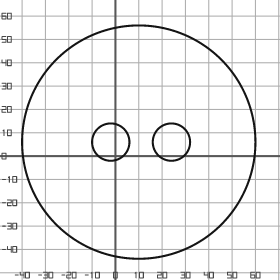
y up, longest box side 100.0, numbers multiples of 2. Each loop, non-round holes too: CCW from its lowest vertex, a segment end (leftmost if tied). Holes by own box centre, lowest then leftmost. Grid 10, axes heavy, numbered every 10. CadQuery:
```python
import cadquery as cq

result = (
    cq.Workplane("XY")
    .moveTo(10.0, 6.0)
    .circle(50.0)
    .moveTo(-2.0, 6.0)
    .circle(8.0)
    .moveTo(24.0, 6.0)
    .circle(8.0)
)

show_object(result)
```